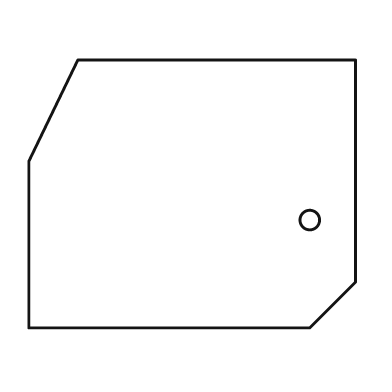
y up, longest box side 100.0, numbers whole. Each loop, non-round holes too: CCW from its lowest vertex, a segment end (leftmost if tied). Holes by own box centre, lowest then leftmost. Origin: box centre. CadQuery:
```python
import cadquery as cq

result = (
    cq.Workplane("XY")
    .moveTo(-50.0, -41.0)
    .lineTo(36.0, -41.0)
    .lineTo(50.0, -27.0)
    .lineTo(50.0, 41.0)
    .lineTo(-35.0, 41.0)
    .lineTo(-50.0, 10.0)
    .close()
    .moveTo(36.0, -8.0)
    .circle(3.0)
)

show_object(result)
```